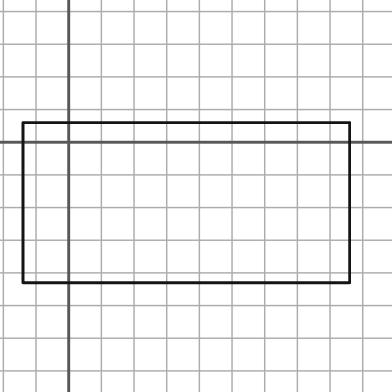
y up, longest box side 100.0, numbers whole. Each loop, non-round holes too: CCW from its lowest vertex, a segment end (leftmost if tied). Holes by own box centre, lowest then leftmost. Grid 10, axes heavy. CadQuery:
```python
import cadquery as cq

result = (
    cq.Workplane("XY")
    .moveTo(-14.0, -43.0)
    .lineTo(86.0, -43.0)
    .lineTo(86.0, 6.0)
    .lineTo(-14.0, 6.0)
    .close()
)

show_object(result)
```